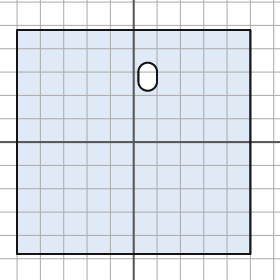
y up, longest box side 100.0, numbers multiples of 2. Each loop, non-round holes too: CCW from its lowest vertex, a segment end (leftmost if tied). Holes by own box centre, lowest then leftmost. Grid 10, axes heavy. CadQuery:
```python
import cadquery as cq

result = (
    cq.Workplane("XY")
    .moveTo(-50.0, -48.0)
    .lineTo(50.0, -48.0)
    .lineTo(50.0, 48.0)
    .lineTo(-50.0, 48.0)
    .close()
    .moveTo(2.0, 26.0)
    .threePointArc((6.0, 22.0), (10.0, 26.0))
    .lineTo(10.0, 30.0)
    .threePointArc((6.0, 34.0), (2.0, 30.0))
    .close()
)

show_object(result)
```